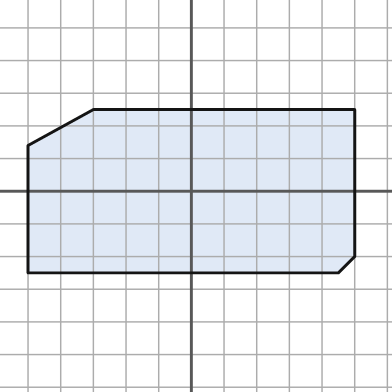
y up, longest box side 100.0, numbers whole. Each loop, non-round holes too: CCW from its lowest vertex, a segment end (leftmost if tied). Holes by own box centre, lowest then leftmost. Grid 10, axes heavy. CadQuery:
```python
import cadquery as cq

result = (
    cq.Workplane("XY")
    .moveTo(-50.0, -25.0)
    .lineTo(45.0, -25.0)
    .lineTo(50.0, -20.0)
    .lineTo(50.0, 25.0)
    .lineTo(-30.0, 25.0)
    .lineTo(-50.0, 14.0)
    .close()
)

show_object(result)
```